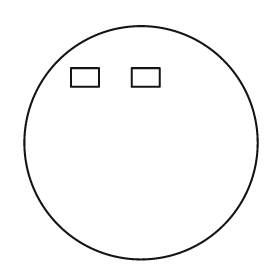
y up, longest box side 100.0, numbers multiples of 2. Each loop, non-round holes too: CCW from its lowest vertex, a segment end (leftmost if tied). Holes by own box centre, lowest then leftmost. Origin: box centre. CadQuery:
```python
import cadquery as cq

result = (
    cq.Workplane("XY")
    .moveTo(0.0, 0.0)
    .circle(50.0)
    .moveTo(-30.0, 24.0)
    .lineTo(-18.0, 24.0)
    .lineTo(-18.0, 32.0)
    .lineTo(-30.0, 32.0)
    .close()
    .moveTo(-4.0, 24.0)
    .lineTo(8.0, 24.0)
    .lineTo(8.0, 32.0)
    .lineTo(-4.0, 32.0)
    .close()
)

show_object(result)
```